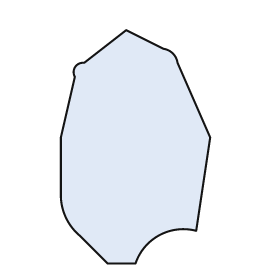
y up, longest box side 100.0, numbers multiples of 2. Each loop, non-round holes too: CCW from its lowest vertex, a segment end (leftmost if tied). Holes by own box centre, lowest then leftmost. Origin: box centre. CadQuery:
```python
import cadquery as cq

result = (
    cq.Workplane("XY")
    .moveTo(-12.0, -50.0)
    .lineTo(0.0, -50.0)
    .threePointArc((10.0, -38.0), (26.0, -36.0))
    .lineTo(32.0, 4.0)
    .lineTo(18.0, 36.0)
    .threePointArc((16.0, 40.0), (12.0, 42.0))
    .lineTo(-4.0, 50.0)
    .lineTo(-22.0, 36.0)
    .threePointArc((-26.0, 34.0), (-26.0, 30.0))
    .lineTo(-32.0, 4.0)
    .lineTo(-32.0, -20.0)
    .threePointArc((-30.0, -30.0), (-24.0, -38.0))
    .close()
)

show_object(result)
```